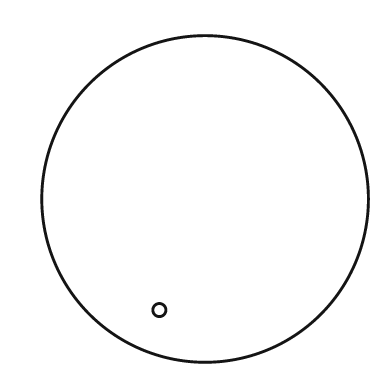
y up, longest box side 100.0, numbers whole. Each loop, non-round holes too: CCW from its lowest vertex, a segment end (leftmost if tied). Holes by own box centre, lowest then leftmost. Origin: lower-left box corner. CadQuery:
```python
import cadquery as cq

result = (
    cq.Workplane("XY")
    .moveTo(50.0, 50.0)
    .circle(50.0)
    .moveTo(36.0, 16.0)
    .circle(2.0)
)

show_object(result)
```